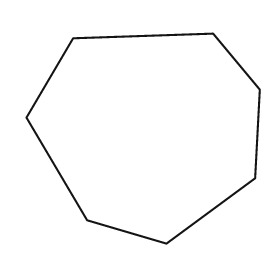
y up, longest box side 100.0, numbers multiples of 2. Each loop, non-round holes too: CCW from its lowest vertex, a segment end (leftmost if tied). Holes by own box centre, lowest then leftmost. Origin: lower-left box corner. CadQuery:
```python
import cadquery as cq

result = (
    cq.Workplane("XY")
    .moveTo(60.0, 0.0)
    .lineTo(98.0, 28.0)
    .lineTo(100.0, 66.0)
    .lineTo(80.0, 90.0)
    .lineTo(20.0, 88.0)
    .lineTo(0.0, 54.0)
    .lineTo(26.0, 10.0)
    .close()
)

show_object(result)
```